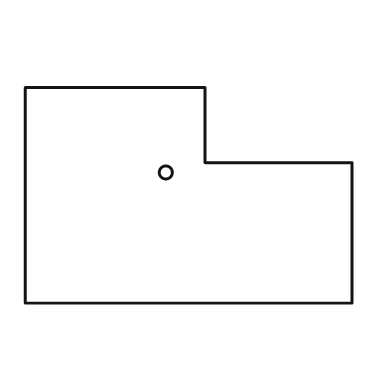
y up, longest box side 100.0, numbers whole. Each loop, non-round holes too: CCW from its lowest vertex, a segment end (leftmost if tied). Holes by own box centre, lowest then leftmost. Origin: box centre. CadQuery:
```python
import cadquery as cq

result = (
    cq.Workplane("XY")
    .moveTo(-50.0, -33.0)
    .lineTo(50.0, -33.0)
    .lineTo(50.0, 10.0)
    .lineTo(5.0, 10.0)
    .lineTo(5.0, 33.0)
    .lineTo(-50.0, 33.0)
    .close()
    .moveTo(-7.0, 7.0)
    .circle(2.0)
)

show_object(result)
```